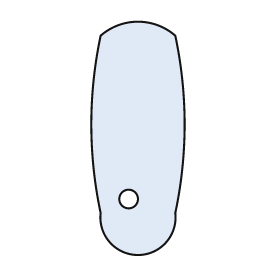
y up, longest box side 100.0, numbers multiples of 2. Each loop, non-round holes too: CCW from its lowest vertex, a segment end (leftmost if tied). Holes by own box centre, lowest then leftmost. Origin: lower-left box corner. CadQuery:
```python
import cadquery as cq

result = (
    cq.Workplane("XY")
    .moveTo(4.0, 18.0)
    .threePointArc((20.0, 0.0), (36.0, 18.0))
    .threePointArc((40.0, 56.0), (36.0, 94.0))
    .threePointArc((20.0, 100.0), (4.0, 94.0))
    .threePointArc((0.0, 56.0), (4.0, 18.0))
    .close()
    .moveTo(16.0, 24.0)
    .circle(4.0)
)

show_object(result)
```